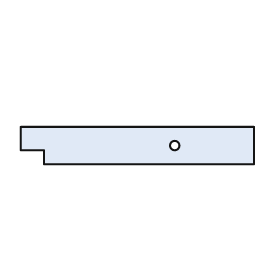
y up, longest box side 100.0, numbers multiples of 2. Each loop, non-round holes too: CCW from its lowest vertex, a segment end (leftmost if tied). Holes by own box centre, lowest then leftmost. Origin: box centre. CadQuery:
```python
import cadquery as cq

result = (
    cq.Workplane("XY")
    .moveTo(-40.0, -8.0)
    .lineTo(50.0, -8.0)
    .lineTo(50.0, 8.0)
    .lineTo(-50.0, 8.0)
    .lineTo(-50.0, -2.0)
    .lineTo(-40.0, -2.0)
    .close()
    .moveTo(16.0, 0.0)
    .circle(2.0)
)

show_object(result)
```